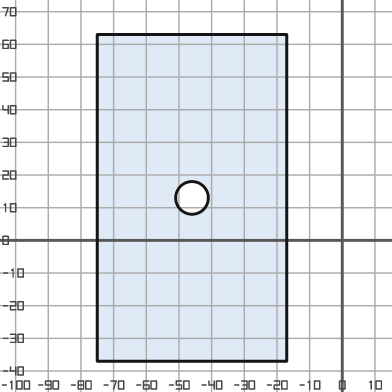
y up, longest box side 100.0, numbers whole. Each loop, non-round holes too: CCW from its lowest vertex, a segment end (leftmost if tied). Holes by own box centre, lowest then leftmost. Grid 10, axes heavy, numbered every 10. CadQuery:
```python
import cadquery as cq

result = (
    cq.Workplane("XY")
    .moveTo(-75.0, -37.0)
    .lineTo(-17.0, -37.0)
    .lineTo(-17.0, 63.0)
    .lineTo(-75.0, 63.0)
    .close()
    .moveTo(-46.0, 13.0)
    .circle(5.0)
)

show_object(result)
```